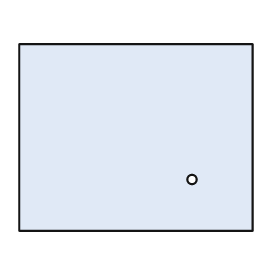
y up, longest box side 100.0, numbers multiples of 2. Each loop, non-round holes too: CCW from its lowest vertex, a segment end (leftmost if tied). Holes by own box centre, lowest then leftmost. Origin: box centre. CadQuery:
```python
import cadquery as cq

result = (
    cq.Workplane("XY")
    .moveTo(-50.0, -40.0)
    .lineTo(50.0, -40.0)
    .lineTo(50.0, 40.0)
    .lineTo(-50.0, 40.0)
    .close()
    .moveTo(24.0, -18.0)
    .circle(2.0)
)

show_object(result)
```